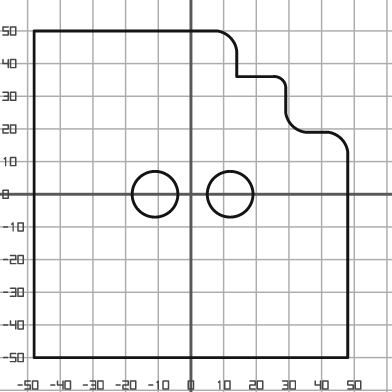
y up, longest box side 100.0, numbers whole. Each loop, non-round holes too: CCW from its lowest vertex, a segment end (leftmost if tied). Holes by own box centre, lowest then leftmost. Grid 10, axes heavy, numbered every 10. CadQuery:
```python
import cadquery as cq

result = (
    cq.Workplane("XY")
    .moveTo(-48.0, -50.0)
    .lineTo(48.0, -50.0)
    .lineTo(48.0, 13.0)
    .threePointArc((46.0, 17.0), (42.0, 19.0))
    .lineTo(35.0, 19.0)
    .threePointArc((31.0, 21.0), (29.0, 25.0))
    .lineTo(29.0, 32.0)
    .threePointArc((28.0, 35.0), (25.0, 36.0))
    .lineTo(14.0, 36.0)
    .lineTo(14.0, 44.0)
    .threePointArc((12.0, 48.0), (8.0, 50.0))
    .lineTo(-48.0, 50.0)
    .close()
    .moveTo(-11.0, 0.0)
    .circle(7.0)
    .moveTo(12.0, 0.0)
    .circle(7.0)
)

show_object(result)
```